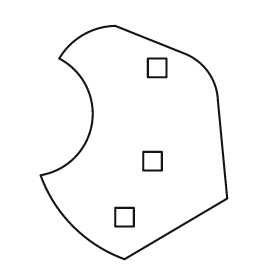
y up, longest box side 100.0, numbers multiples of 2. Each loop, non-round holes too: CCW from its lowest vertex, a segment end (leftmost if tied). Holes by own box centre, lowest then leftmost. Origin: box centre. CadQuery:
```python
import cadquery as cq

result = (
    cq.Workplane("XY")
    .moveTo(-4.0, -50.0)
    .lineTo(40.0, -24.0)
    .lineTo(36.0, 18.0)
    .threePointArc((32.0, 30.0), (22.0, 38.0))
    .lineTo(-8.0, 50.0)
    .threePointArc((-22.0, 46.0), (-32.0, 36.0))
    .threePointArc((-18.0, 8.0), (-40.0, -14.0))
    .threePointArc((-26.0, -36.0), (-4.0, -50.0))
    .close()
    .moveTo(-8.0, -36.0)
    .lineTo(0.0, -36.0)
    .lineTo(0.0, -28.0)
    .lineTo(-8.0, -28.0)
    .close()
    .moveTo(4.0, -12.0)
    .lineTo(12.0, -12.0)
    .lineTo(12.0, -4.0)
    .lineTo(4.0, -4.0)
    .close()
    .moveTo(6.0, 28.0)
    .lineTo(14.0, 28.0)
    .lineTo(14.0, 36.0)
    .lineTo(6.0, 36.0)
    .close()
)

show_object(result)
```